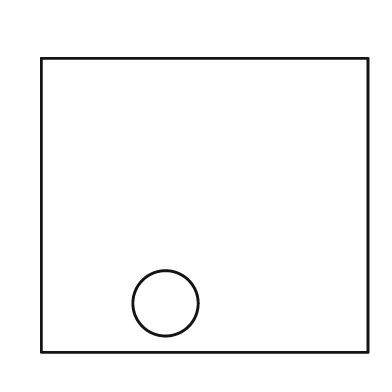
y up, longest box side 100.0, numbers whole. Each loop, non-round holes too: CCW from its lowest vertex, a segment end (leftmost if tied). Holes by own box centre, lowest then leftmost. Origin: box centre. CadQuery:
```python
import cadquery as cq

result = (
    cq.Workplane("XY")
    .moveTo(-50.0, -45.0)
    .lineTo(50.0, -45.0)
    .lineTo(50.0, 45.0)
    .lineTo(-50.0, 45.0)
    .close()
    .moveTo(-12.0, -30.0)
    .circle(10.0)
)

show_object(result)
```